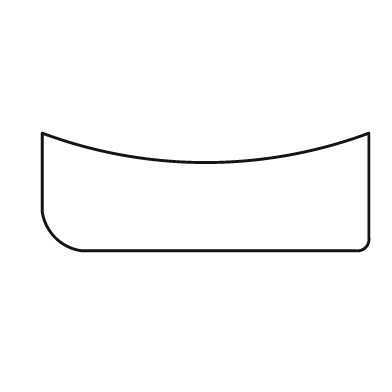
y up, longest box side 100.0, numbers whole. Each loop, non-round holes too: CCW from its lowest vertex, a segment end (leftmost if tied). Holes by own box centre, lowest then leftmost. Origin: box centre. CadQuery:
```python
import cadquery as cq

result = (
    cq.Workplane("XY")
    .moveTo(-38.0, -18.0)
    .lineTo(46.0, -18.0)
    .threePointArc((49.0, -17.0), (50.0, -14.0))
    .lineTo(50.0, 18.0)
    .threePointArc((0.0, 9.0), (-50.0, 18.0))
    .lineTo(-50.0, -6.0)
    .threePointArc((-46.0, -14.0), (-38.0, -18.0))
    .close()
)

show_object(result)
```